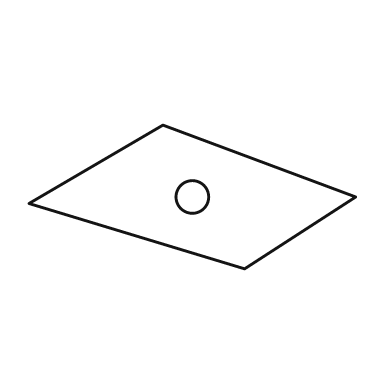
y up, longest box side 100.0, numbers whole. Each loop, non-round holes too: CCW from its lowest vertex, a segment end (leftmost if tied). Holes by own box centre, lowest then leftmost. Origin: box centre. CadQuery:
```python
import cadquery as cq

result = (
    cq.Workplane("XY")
    .moveTo(16.0, -22.0)
    .lineTo(50.0, 0.0)
    .lineTo(-9.0, 22.0)
    .lineTo(-50.0, -2.0)
    .close()
    .moveTo(0.0, 0.0)
    .circle(5.0)
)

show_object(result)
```